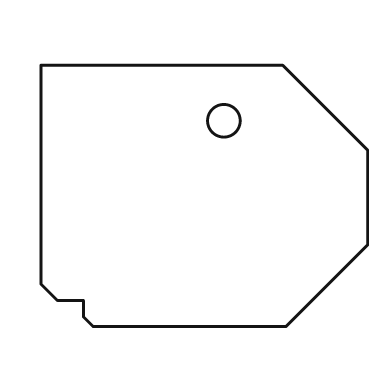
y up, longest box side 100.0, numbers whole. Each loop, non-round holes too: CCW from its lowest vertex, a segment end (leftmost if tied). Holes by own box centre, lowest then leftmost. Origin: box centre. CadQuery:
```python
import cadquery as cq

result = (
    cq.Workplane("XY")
    .moveTo(-34.0, -40.0)
    .lineTo(25.0, -40.0)
    .lineTo(50.0, -15.0)
    .lineTo(50.0, 14.0)
    .lineTo(24.0, 40.0)
    .lineTo(-50.0, 40.0)
    .lineTo(-50.0, -27.0)
    .lineTo(-45.0, -32.0)
    .lineTo(-37.0, -32.0)
    .lineTo(-37.0, -37.0)
    .close()
    .moveTo(6.0, 23.0)
    .circle(5.0)
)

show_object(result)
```